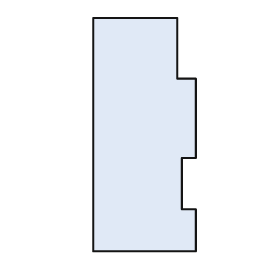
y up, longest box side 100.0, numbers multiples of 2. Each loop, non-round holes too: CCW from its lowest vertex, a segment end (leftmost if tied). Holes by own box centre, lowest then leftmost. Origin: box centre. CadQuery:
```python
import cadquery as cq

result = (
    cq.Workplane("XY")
    .moveTo(-22.0, -50.0)
    .lineTo(22.0, -50.0)
    .lineTo(22.0, -32.0)
    .lineTo(16.0, -32.0)
    .lineTo(16.0, -10.0)
    .lineTo(22.0, -10.0)
    .lineTo(22.0, 24.0)
    .lineTo(14.0, 24.0)
    .lineTo(14.0, 50.0)
    .lineTo(-22.0, 50.0)
    .close()
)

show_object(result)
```